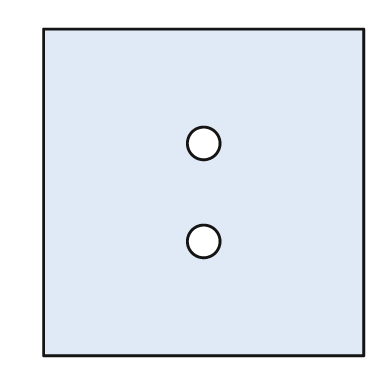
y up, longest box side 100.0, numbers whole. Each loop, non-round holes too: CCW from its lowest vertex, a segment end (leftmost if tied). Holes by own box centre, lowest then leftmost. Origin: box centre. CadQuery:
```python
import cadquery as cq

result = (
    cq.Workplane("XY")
    .moveTo(-49.0, -50.0)
    .lineTo(49.0, -50.0)
    .lineTo(49.0, 50.0)
    .lineTo(-49.0, 50.0)
    .close()
    .moveTo(0.0, -15.0)
    .circle(5.0)
    .moveTo(0.0, 15.0)
    .circle(5.0)
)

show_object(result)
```